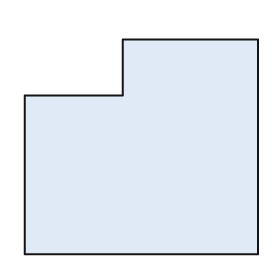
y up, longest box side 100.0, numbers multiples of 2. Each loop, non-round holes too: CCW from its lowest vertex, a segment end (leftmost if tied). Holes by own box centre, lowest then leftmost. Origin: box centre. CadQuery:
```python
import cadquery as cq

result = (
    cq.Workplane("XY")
    .moveTo(-50.0, -46.0)
    .lineTo(50.0, -46.0)
    .lineTo(50.0, 46.0)
    .lineTo(-8.0, 46.0)
    .lineTo(-8.0, 22.0)
    .lineTo(-50.0, 22.0)
    .close()
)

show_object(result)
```